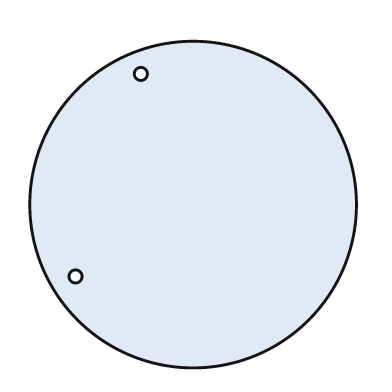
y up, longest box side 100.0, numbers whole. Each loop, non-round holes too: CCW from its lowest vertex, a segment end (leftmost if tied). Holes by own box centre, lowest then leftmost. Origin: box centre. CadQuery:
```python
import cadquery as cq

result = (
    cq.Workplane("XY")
    .moveTo(0.0, 0.0)
    .circle(50.0)
    .moveTo(-36.0, -22.0)
    .circle(2.0)
    .moveTo(-16.0, 40.0)
    .circle(2.0)
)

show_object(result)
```